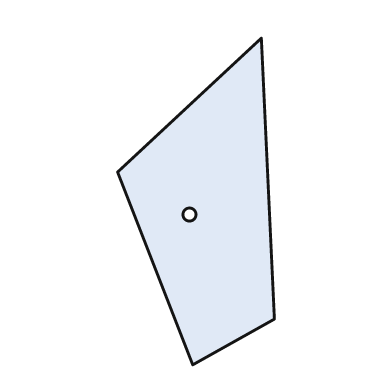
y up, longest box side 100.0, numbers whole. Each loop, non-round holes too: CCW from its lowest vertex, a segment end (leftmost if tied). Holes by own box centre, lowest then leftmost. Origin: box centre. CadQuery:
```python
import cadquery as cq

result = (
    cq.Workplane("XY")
    .moveTo(-1.0, -50.0)
    .lineTo(24.0, -36.0)
    .lineTo(20.0, 50.0)
    .lineTo(-24.0, 9.0)
    .close()
    .moveTo(-2.0, -4.0)
    .circle(2.0)
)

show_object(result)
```